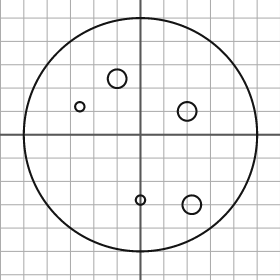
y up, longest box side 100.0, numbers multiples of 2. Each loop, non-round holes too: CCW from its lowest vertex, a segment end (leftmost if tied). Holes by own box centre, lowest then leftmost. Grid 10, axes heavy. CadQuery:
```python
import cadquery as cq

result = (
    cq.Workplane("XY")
    .moveTo(0.0, 0.0)
    .circle(50.0)
    .moveTo(22.0, -30.0)
    .circle(4.0)
    .moveTo(0.0, -28.0)
    .circle(2.0)
    .moveTo(20.0, 10.0)
    .circle(4.0)
    .moveTo(-26.0, 12.0)
    .circle(2.0)
    .moveTo(-10.0, 24.0)
    .circle(4.0)
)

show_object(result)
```